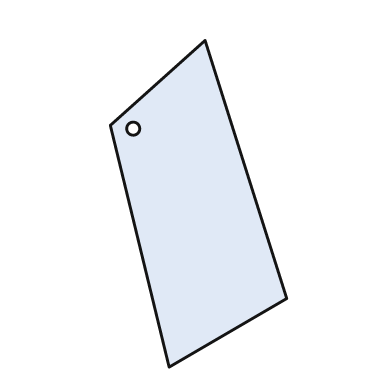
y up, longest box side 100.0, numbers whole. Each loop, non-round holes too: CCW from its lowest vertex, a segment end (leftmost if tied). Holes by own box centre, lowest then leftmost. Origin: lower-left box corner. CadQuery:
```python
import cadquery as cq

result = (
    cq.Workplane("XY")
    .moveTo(18.0, 0.0)
    .lineTo(54.0, 21.0)
    .lineTo(29.0, 100.0)
    .lineTo(0.0, 74.0)
    .close()
    .moveTo(7.0, 73.0)
    .circle(2.0)
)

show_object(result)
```